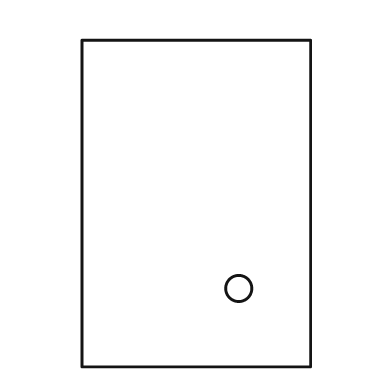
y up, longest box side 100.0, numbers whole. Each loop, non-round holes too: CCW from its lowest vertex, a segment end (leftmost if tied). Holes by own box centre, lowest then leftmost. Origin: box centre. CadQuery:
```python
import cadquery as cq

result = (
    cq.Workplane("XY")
    .moveTo(-35.0, -50.0)
    .lineTo(35.0, -50.0)
    .lineTo(35.0, 50.0)
    .lineTo(-35.0, 50.0)
    .close()
    .moveTo(13.0, -26.0)
    .circle(4.0)
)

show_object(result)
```